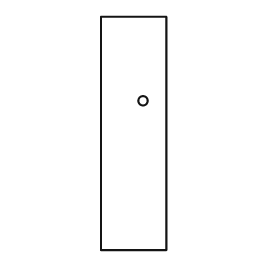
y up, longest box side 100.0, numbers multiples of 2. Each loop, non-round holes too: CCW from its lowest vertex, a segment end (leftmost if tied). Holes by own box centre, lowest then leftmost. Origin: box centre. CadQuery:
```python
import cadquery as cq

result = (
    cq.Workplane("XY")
    .moveTo(-14.0, -50.0)
    .lineTo(14.0, -50.0)
    .lineTo(14.0, 50.0)
    .lineTo(-14.0, 50.0)
    .close()
    .moveTo(4.0, 14.0)
    .circle(2.0)
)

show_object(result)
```